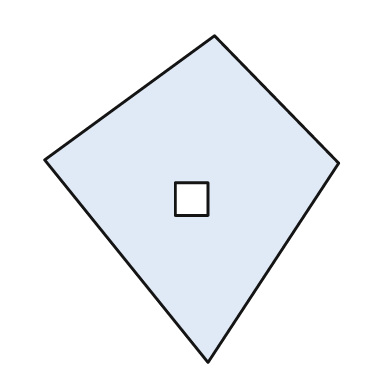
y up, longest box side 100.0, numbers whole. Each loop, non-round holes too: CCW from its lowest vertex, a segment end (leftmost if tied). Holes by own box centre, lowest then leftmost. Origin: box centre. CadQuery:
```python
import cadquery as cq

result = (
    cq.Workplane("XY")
    .moveTo(5.0, -50.0)
    .lineTo(45.0, 11.0)
    .lineTo(7.0, 50.0)
    .lineTo(-45.0, 12.0)
    .close()
    .moveTo(-5.0, -5.0)
    .lineTo(5.0, -5.0)
    .lineTo(5.0, 5.0)
    .lineTo(-5.0, 5.0)
    .close()
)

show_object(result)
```